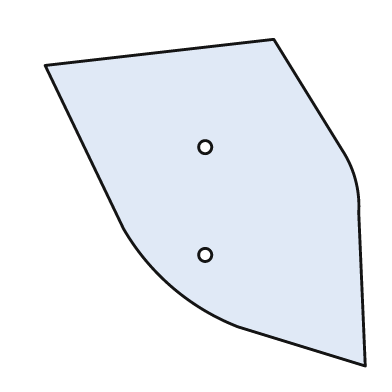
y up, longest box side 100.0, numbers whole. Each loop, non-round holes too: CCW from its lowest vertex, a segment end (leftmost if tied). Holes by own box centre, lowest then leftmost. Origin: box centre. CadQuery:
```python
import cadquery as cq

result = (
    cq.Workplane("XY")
    .moveTo(49.0, -50.0)
    .lineTo(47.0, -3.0)
    .threePointArc((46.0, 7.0), (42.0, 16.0))
    .lineTo(21.0, 50.0)
    .lineTo(-49.0, 42.0)
    .lineTo(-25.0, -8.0)
    .threePointArc((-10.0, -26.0), (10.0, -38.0))
    .close()
    .moveTo(0.0, -16.0)
    .circle(2.0)
    .moveTo(0.0, 17.0)
    .circle(2.0)
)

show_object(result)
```